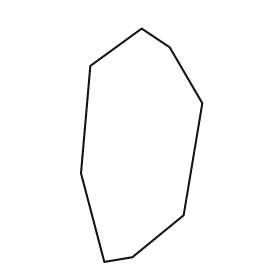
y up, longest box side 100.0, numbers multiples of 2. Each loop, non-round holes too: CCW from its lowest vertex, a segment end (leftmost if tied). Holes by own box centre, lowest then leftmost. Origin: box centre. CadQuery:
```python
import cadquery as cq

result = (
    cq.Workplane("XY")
    .moveTo(-16.0, -50.0)
    .lineTo(-4.0, -48.0)
    .lineTo(18.0, -30.0)
    .lineTo(26.0, 18.0)
    .lineTo(12.0, 42.0)
    .lineTo(0.0, 50.0)
    .lineTo(-22.0, 34.0)
    .lineTo(-26.0, -12.0)
    .close()
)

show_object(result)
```